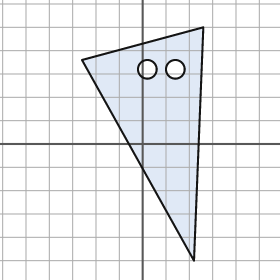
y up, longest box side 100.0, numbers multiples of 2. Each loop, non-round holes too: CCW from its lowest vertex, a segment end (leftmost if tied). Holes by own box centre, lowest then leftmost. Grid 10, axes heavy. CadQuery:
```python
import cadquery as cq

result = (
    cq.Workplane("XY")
    .moveTo(22.0, -50.0)
    .lineTo(26.0, 50.0)
    .lineTo(-26.0, 36.0)
    .close()
    .moveTo(2.0, 32.0)
    .circle(4.0)
    .moveTo(14.0, 32.0)
    .circle(4.0)
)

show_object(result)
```